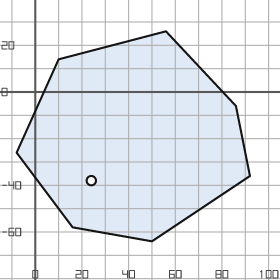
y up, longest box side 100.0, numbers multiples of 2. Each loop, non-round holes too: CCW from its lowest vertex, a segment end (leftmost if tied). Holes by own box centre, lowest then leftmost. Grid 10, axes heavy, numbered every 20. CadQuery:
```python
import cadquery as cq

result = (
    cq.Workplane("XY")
    .moveTo(50.0, -64.0)
    .lineTo(92.0, -36.0)
    .lineTo(86.0, -6.0)
    .lineTo(56.0, 26.0)
    .lineTo(10.0, 14.0)
    .lineTo(-8.0, -26.0)
    .lineTo(16.0, -58.0)
    .close()
    .moveTo(24.0, -38.0)
    .circle(2.0)
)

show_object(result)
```